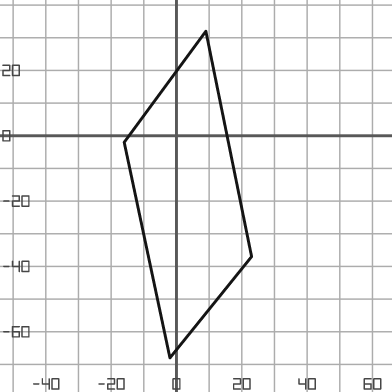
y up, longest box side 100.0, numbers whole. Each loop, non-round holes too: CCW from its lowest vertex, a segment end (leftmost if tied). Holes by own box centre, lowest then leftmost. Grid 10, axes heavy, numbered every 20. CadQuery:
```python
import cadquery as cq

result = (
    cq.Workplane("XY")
    .moveTo(-2.0, -68.0)
    .lineTo(23.0, -37.0)
    .lineTo(9.0, 32.0)
    .lineTo(-16.0, -2.0)
    .close()
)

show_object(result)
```